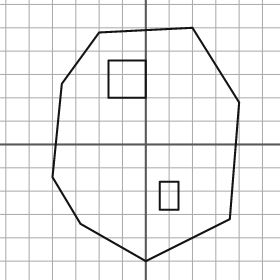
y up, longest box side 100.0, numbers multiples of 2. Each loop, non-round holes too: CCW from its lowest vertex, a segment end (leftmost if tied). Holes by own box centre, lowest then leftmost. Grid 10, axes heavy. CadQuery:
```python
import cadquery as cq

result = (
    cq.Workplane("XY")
    .moveTo(0.0, -50.0)
    .lineTo(36.0, -32.0)
    .lineTo(40.0, 18.0)
    .lineTo(20.0, 50.0)
    .lineTo(-20.0, 48.0)
    .lineTo(-36.0, 26.0)
    .lineTo(-40.0, -14.0)
    .lineTo(-28.0, -34.0)
    .close()
    .moveTo(6.0, -28.0)
    .lineTo(14.0, -28.0)
    .lineTo(14.0, -16.0)
    .lineTo(6.0, -16.0)
    .close()
    .moveTo(-16.0, 20.0)
    .lineTo(0.0, 20.0)
    .lineTo(0.0, 36.0)
    .lineTo(-16.0, 36.0)
    .close()
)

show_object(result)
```